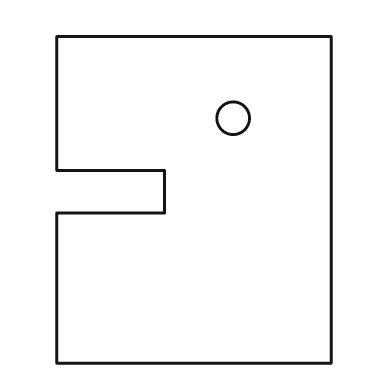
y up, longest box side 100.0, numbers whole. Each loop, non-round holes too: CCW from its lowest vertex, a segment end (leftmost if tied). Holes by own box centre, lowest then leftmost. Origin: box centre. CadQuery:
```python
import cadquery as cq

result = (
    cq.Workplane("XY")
    .moveTo(-42.0, -50.0)
    .lineTo(42.0, -50.0)
    .lineTo(42.0, 50.0)
    .lineTo(-42.0, 50.0)
    .lineTo(-42.0, 9.0)
    .lineTo(-9.0, 9.0)
    .lineTo(-9.0, -4.0)
    .lineTo(-42.0, -4.0)
    .close()
    .moveTo(12.0, 25.0)
    .circle(5.0)
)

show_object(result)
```